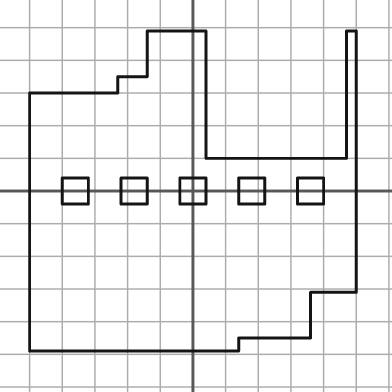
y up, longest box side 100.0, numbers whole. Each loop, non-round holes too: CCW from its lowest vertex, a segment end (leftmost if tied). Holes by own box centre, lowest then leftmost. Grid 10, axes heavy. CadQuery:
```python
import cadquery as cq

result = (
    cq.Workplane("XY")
    .moveTo(-50.0, -49.0)
    .lineTo(14.0, -49.0)
    .lineTo(14.0, -45.0)
    .lineTo(36.0, -45.0)
    .lineTo(36.0, -31.0)
    .lineTo(50.0, -31.0)
    .lineTo(50.0, 49.0)
    .lineTo(47.0, 49.0)
    .lineTo(47.0, 10.0)
    .lineTo(4.0, 10.0)
    .lineTo(4.0, 49.0)
    .lineTo(-14.0, 49.0)
    .lineTo(-14.0, 35.0)
    .lineTo(-23.0, 35.0)
    .lineTo(-23.0, 30.0)
    .lineTo(-50.0, 30.0)
    .close()
    .moveTo(-40.0, -4.0)
    .lineTo(-32.0, -4.0)
    .lineTo(-32.0, 4.0)
    .lineTo(-40.0, 4.0)
    .close()
    .moveTo(-22.0, -4.0)
    .lineTo(-14.0, -4.0)
    .lineTo(-14.0, 4.0)
    .lineTo(-22.0, 4.0)
    .close()
    .moveTo(-4.0, -4.0)
    .lineTo(4.0, -4.0)
    .lineTo(4.0, 4.0)
    .lineTo(-4.0, 4.0)
    .close()
    .moveTo(14.0, -4.0)
    .lineTo(22.0, -4.0)
    .lineTo(22.0, 4.0)
    .lineTo(14.0, 4.0)
    .close()
    .moveTo(32.0, -4.0)
    .lineTo(40.0, -4.0)
    .lineTo(40.0, 4.0)
    .lineTo(32.0, 4.0)
    .close()
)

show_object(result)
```